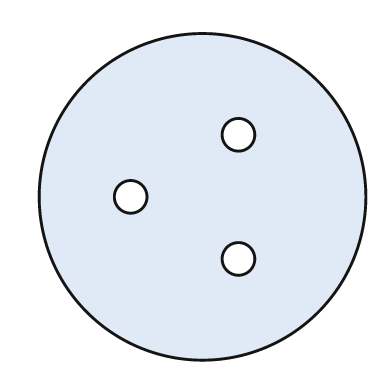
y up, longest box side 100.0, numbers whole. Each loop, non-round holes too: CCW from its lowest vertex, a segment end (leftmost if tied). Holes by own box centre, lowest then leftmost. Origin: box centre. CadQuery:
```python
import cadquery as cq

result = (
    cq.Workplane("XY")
    .moveTo(0.0, 0.0)
    .circle(50.0)
    .moveTo(11.0, -19.0)
    .circle(5.0)
    .moveTo(-22.0, 0.0)
    .circle(5.0)
    .moveTo(11.0, 19.0)
    .circle(5.0)
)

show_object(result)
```